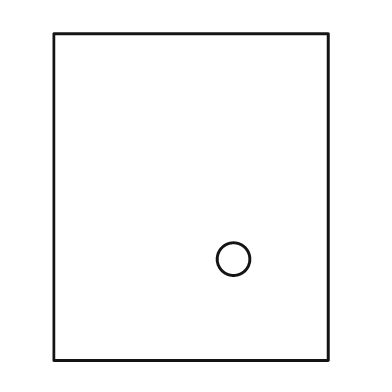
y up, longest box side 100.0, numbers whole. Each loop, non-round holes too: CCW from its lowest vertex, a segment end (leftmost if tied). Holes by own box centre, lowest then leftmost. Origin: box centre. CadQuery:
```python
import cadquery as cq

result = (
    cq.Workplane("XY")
    .moveTo(-42.0, -50.0)
    .lineTo(42.0, -50.0)
    .lineTo(42.0, 50.0)
    .lineTo(-42.0, 50.0)
    .close()
    .moveTo(13.0, -19.0)
    .circle(5.0)
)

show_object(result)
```